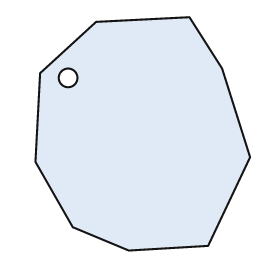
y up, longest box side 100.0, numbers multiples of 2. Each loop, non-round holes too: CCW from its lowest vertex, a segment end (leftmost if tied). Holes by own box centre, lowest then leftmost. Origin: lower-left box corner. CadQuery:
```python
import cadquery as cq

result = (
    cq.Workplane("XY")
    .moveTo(40.0, 0.0)
    .lineTo(74.0, 2.0)
    .lineTo(92.0, 40.0)
    .lineTo(80.0, 78.0)
    .lineTo(66.0, 100.0)
    .lineTo(26.0, 98.0)
    .lineTo(2.0, 76.0)
    .lineTo(0.0, 38.0)
    .lineTo(16.0, 10.0)
    .close()
    .moveTo(14.0, 74.0)
    .circle(4.0)
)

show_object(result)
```